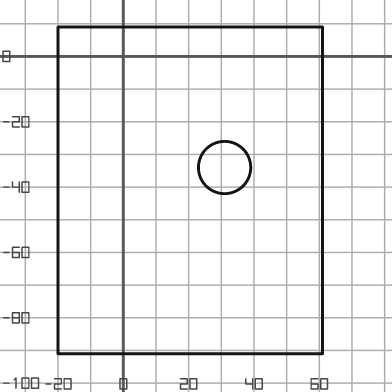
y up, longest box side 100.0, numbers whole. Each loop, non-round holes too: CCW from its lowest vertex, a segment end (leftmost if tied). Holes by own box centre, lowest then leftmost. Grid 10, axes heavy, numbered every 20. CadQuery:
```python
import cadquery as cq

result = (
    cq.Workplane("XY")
    .moveTo(-20.0, -91.0)
    .lineTo(61.0, -91.0)
    .lineTo(61.0, 9.0)
    .lineTo(-20.0, 9.0)
    .close()
    .moveTo(31.0, -34.0)
    .circle(8.0)
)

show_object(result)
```